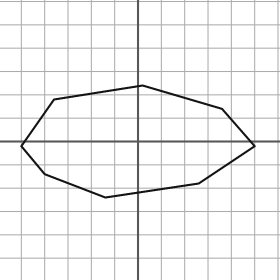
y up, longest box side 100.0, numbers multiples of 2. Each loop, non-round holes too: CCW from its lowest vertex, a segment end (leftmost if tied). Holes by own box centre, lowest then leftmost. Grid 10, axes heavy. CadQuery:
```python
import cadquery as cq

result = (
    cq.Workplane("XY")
    .moveTo(-14.0, -24.0)
    .lineTo(26.0, -18.0)
    .lineTo(50.0, -2.0)
    .lineTo(36.0, 14.0)
    .lineTo(2.0, 24.0)
    .lineTo(-36.0, 18.0)
    .lineTo(-50.0, -2.0)
    .lineTo(-40.0, -14.0)
    .close()
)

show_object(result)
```